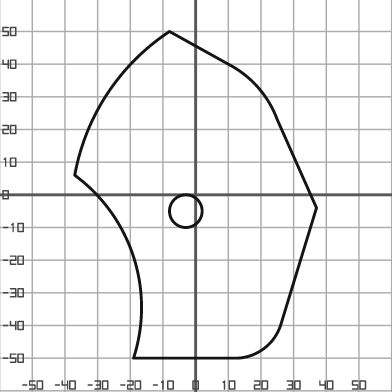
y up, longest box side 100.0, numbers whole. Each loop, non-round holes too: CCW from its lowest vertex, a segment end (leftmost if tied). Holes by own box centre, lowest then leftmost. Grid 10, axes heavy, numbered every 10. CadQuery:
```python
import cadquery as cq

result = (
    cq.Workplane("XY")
    .moveTo(-19.0, -50.0)
    .lineTo(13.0, -50.0)
    .threePointArc((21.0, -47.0), (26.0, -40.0))
    .lineTo(37.0, -4.0)
    .lineTo(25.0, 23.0)
    .threePointArc((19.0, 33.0), (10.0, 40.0))
    .lineTo(-8.0, 50.0)
    .threePointArc((-27.0, 31.0), (-37.0, 6.0))
    .threePointArc((-19.0, -19.0), (-19.0, -50.0))
    .close()
    .moveTo(-3.0, -5.0)
    .circle(5.0)
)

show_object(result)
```